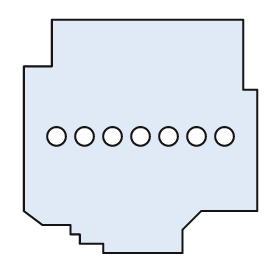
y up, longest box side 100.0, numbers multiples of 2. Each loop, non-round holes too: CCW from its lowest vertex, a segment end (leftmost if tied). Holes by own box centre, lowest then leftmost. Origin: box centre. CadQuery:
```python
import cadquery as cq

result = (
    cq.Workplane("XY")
    .moveTo(-16.0, -50.0)
    .lineTo(18.0, -50.0)
    .lineTo(18.0, -40.0)
    .lineTo(26.0, -32.0)
    .lineTo(50.0, -32.0)
    .lineTo(50.0, 20.0)
    .lineTo(44.0, 20.0)
    .lineTo(44.0, 50.0)
    .lineTo(-38.0, 50.0)
    .lineTo(-38.0, 30.0)
    .lineTo(-50.0, 30.0)
    .lineTo(-50.0, -32.0)
    .lineTo(-42.0, -38.0)
    .lineTo(-30.0, -38.0)
    .lineTo(-30.0, -42.0)
    .lineTo(-26.0, -42.0)
    .lineTo(-26.0, -46.0)
    .lineTo(-16.0, -46.0)
    .close()
    .moveTo(-36.0, 0.0)
    .circle(4.0)
    .moveTo(-24.0, 0.0)
    .circle(4.0)
    .moveTo(-12.0, 0.0)
    .circle(4.0)
    .moveTo(0.0, 0.0)
    .circle(4.0)
    .moveTo(12.0, 0.0)
    .circle(4.0)
    .moveTo(24.0, 0.0)
    .circle(4.0)
    .moveTo(36.0, 0.0)
    .circle(4.0)
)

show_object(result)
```